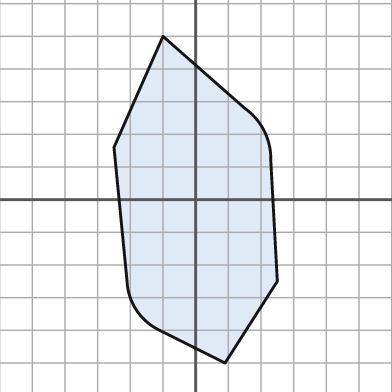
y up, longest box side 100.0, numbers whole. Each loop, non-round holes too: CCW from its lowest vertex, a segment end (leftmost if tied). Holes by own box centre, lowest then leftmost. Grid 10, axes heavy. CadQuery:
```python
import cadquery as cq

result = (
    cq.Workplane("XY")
    .moveTo(9.0, -50.0)
    .lineTo(25.0, -25.0)
    .lineTo(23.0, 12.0)
    .threePointArc((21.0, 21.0), (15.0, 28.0))
    .lineTo(-10.0, 50.0)
    .lineTo(-25.0, 16.0)
    .lineTo(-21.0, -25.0)
    .threePointArc((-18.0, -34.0), (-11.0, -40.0))
    .close()
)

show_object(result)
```